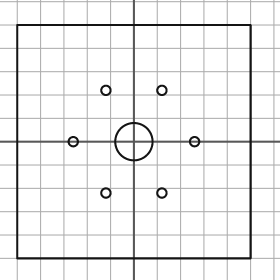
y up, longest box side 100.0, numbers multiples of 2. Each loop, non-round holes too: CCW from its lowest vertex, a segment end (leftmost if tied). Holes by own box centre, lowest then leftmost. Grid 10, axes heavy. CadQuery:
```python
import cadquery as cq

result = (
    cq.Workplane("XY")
    .moveTo(-50.0, -50.0)
    .lineTo(50.0, -50.0)
    .lineTo(50.0, 50.0)
    .lineTo(-50.0, 50.0)
    .close()
    .moveTo(-12.0, -22.0)
    .circle(2.0)
    .moveTo(12.0, -22.0)
    .circle(2.0)
    .moveTo(-26.0, 0.0)
    .circle(2.0)
    .moveTo(0.0, 0.0)
    .circle(8.0)
    .moveTo(26.0, 0.0)
    .circle(2.0)
    .moveTo(-12.0, 22.0)
    .circle(2.0)
    .moveTo(12.0, 22.0)
    .circle(2.0)
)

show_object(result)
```